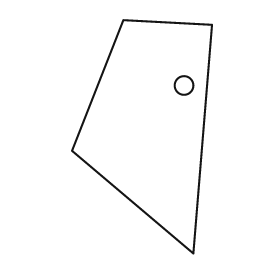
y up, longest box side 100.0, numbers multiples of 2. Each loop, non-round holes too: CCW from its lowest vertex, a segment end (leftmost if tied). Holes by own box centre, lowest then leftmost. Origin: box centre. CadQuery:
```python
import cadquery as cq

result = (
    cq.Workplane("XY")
    .moveTo(22.0, -50.0)
    .lineTo(30.0, 48.0)
    .lineTo(-8.0, 50.0)
    .lineTo(-30.0, -6.0)
    .close()
    .moveTo(18.0, 22.0)
    .circle(4.0)
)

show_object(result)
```